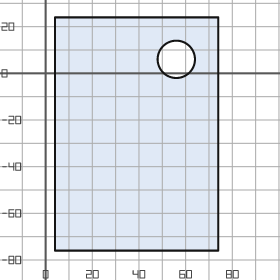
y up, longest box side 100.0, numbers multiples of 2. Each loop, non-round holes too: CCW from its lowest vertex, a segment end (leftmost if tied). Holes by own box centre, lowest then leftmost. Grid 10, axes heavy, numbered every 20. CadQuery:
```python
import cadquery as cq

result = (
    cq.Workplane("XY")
    .moveTo(4.0, -76.0)
    .lineTo(74.0, -76.0)
    .lineTo(74.0, 24.0)
    .lineTo(4.0, 24.0)
    .close()
    .moveTo(56.0, 6.0)
    .circle(8.0)
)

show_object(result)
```